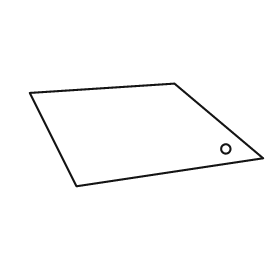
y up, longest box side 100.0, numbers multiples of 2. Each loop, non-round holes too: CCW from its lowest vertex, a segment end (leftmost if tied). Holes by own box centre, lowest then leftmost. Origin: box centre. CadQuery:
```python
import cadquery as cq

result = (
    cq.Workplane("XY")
    .moveTo(-30.0, -22.0)
    .lineTo(50.0, -10.0)
    .lineTo(12.0, 22.0)
    .lineTo(-50.0, 18.0)
    .close()
    .moveTo(34.0, -6.0)
    .circle(2.0)
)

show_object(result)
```